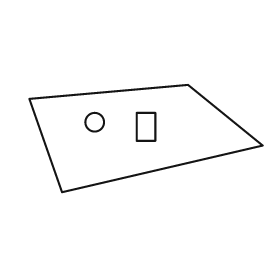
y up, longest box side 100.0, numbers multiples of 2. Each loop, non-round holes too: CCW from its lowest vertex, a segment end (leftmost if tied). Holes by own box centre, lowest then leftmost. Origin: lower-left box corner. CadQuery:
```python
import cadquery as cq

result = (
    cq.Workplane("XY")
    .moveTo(14.0, 0.0)
    .lineTo(100.0, 20.0)
    .lineTo(68.0, 46.0)
    .lineTo(0.0, 40.0)
    .close()
    .moveTo(46.0, 22.0)
    .lineTo(54.0, 22.0)
    .lineTo(54.0, 34.0)
    .lineTo(46.0, 34.0)
    .close()
    .moveTo(28.0, 30.0)
    .circle(4.0)
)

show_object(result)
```